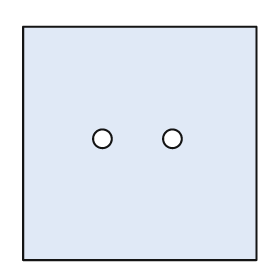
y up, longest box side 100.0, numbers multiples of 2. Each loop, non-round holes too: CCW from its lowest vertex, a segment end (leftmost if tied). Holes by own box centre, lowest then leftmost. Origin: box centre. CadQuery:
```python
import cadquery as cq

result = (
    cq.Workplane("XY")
    .moveTo(-50.0, -50.0)
    .lineTo(50.0, -50.0)
    .lineTo(50.0, 50.0)
    .lineTo(-50.0, 50.0)
    .close()
    .moveTo(-16.0, 2.0)
    .circle(4.0)
    .moveTo(14.0, 2.0)
    .circle(4.0)
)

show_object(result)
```